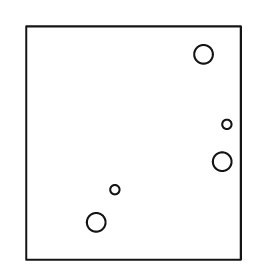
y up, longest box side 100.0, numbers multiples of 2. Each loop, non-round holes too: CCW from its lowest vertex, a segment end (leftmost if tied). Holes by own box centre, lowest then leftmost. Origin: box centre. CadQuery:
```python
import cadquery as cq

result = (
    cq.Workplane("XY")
    .moveTo(-46.0, -50.0)
    .lineTo(46.0, -50.0)
    .lineTo(46.0, 50.0)
    .lineTo(-46.0, 50.0)
    .close()
    .moveTo(-16.0, -34.0)
    .circle(4.0)
    .moveTo(-8.0, -20.0)
    .circle(2.0)
    .moveTo(38.0, -8.0)
    .circle(4.0)
    .moveTo(40.0, 8.0)
    .circle(2.0)
    .moveTo(30.0, 38.0)
    .circle(4.0)
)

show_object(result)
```